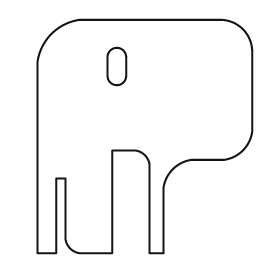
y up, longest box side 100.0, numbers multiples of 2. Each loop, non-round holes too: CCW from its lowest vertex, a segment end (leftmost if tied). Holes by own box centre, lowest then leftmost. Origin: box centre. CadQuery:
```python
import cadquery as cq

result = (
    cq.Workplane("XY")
    .moveTo(-46.0, -50.0)
    .lineTo(-38.0, -50.0)
    .lineTo(-38.0, -18.0)
    .lineTo(-34.0, -18.0)
    .lineTo(-34.0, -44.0)
    .threePointArc((-32.0, -48.0), (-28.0, -50.0))
    .lineTo(-14.0, -50.0)
    .lineTo(-14.0, -6.0)
    .lineTo(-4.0, -6.0)
    .threePointArc((0.0, -8.0), (2.0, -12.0))
    .lineTo(2.0, -50.0)
    .lineTo(8.0, -50.0)
    .lineTo(8.0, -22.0)
    .threePointArc((12.0, -14.0), (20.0, -10.0))
    .lineTo(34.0, -10.0)
    .threePointArc((42.0, -6.0), (46.0, 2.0))
    .lineTo(46.0, 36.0)
    .threePointArc((42.0, 46.0), (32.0, 50.0))
    .lineTo(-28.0, 50.0)
    .threePointArc((-40.0, 44.0), (-46.0, 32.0))
    .close()
    .moveTo(-16.0, 26.0)
    .threePointArc((-12.0, 22.0), (-8.0, 26.0))
    .lineTo(-8.0, 34.0)
    .threePointArc((-12.0, 38.0), (-16.0, 34.0))
    .close()
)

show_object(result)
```